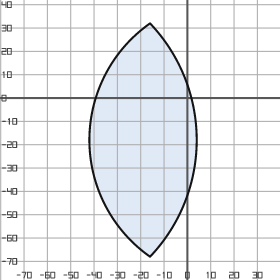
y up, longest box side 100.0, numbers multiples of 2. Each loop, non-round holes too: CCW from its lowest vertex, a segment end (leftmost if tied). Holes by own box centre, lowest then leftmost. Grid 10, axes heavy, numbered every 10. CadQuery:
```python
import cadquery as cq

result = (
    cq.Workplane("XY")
    .moveTo(-16.0, -68.0)
    .threePointArc((4.0, -18.0), (-16.0, 32.0))
    .threePointArc((-42.0, -18.0), (-16.0, -68.0))
    .close()
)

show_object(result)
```